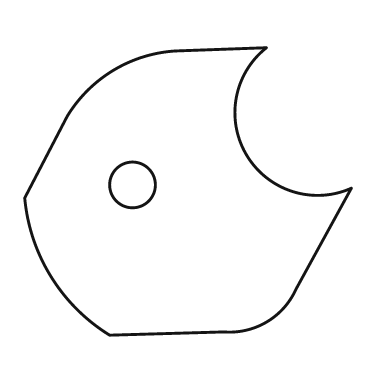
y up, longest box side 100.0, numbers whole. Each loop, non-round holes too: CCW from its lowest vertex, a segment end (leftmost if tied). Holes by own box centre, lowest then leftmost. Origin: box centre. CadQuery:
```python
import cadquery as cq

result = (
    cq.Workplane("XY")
    .moveTo(-24.0, -44.0)
    .lineTo(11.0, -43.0)
    .threePointArc((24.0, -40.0), (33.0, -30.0))
    .lineTo(50.0, 1.0)
    .threePointArc((18.0, 11.0), (24.0, 44.0))
    .lineTo(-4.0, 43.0)
    .threePointArc((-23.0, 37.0), (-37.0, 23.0))
    .lineTo(-50.0, -2.0)
    .threePointArc((-42.0, -26.0), (-24.0, -44.0))
    .close()
    .moveTo(-17.0, 2.0)
    .circle(7.0)
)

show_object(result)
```